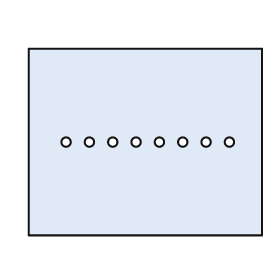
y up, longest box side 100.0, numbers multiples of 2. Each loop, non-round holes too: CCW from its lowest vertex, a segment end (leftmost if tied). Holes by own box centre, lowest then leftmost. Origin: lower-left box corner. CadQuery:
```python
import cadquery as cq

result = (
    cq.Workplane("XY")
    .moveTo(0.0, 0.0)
    .lineTo(100.0, 0.0)
    .lineTo(100.0, 80.0)
    .lineTo(0.0, 80.0)
    .close()
    .moveTo(16.0, 40.0)
    .circle(2.0)
    .moveTo(26.0, 40.0)
    .circle(2.0)
    .moveTo(36.0, 40.0)
    .circle(2.0)
    .moveTo(46.0, 40.0)
    .circle(2.0)
    .moveTo(56.0, 40.0)
    .circle(2.0)
    .moveTo(66.0, 40.0)
    .circle(2.0)
    .moveTo(76.0, 40.0)
    .circle(2.0)
    .moveTo(86.0, 40.0)
    .circle(2.0)
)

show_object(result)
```